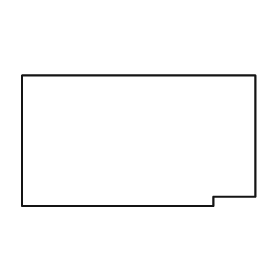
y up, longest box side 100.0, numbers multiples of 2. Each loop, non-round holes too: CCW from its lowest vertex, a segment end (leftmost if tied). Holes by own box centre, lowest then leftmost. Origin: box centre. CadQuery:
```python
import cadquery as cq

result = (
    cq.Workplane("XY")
    .moveTo(-50.0, -28.0)
    .lineTo(32.0, -28.0)
    .lineTo(32.0, -24.0)
    .lineTo(50.0, -24.0)
    .lineTo(50.0, 28.0)
    .lineTo(-50.0, 28.0)
    .close()
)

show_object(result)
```